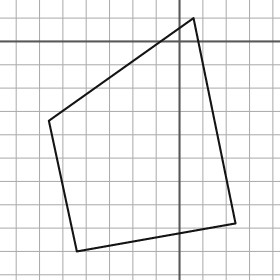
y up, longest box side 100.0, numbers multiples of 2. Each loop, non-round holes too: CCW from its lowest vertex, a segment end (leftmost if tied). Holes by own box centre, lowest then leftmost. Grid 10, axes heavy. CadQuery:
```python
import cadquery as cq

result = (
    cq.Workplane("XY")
    .moveTo(-44.0, -90.0)
    .lineTo(24.0, -78.0)
    .lineTo(6.0, 10.0)
    .lineTo(-56.0, -34.0)
    .close()
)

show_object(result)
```